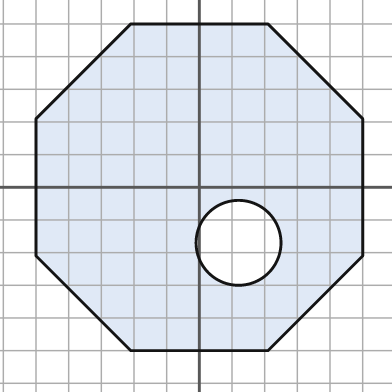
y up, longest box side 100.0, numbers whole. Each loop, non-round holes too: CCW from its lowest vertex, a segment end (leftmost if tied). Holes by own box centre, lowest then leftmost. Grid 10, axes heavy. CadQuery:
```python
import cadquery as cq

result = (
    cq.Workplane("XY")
    .moveTo(-21.0, -50.0)
    .lineTo(21.0, -50.0)
    .lineTo(50.0, -21.0)
    .lineTo(50.0, 21.0)
    .lineTo(21.0, 50.0)
    .lineTo(-21.0, 50.0)
    .lineTo(-50.0, 21.0)
    .lineTo(-50.0, -21.0)
    .close()
    .moveTo(12.0, -17.0)
    .circle(13.0)
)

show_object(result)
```